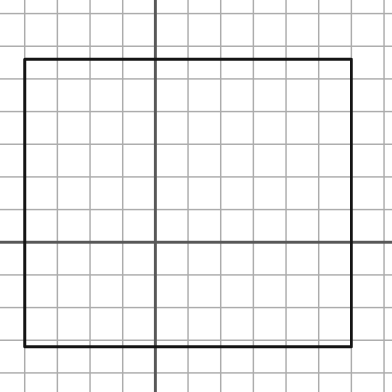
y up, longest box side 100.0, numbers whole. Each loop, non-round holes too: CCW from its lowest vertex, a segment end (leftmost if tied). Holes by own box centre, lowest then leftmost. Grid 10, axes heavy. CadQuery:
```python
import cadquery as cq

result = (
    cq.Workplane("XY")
    .moveTo(-40.0, -32.0)
    .lineTo(60.0, -32.0)
    .lineTo(60.0, 56.0)
    .lineTo(-40.0, 56.0)
    .close()
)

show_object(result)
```